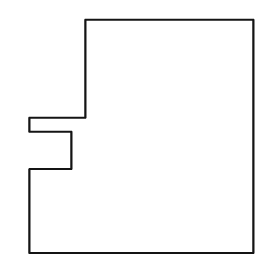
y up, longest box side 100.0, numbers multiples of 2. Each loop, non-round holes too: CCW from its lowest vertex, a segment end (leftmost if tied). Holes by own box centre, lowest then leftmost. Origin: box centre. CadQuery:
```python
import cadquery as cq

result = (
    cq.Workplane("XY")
    .moveTo(-48.0, -50.0)
    .lineTo(48.0, -50.0)
    .lineTo(48.0, 50.0)
    .lineTo(-24.0, 50.0)
    .lineTo(-24.0, 8.0)
    .lineTo(-48.0, 8.0)
    .lineTo(-48.0, 2.0)
    .lineTo(-30.0, 2.0)
    .lineTo(-30.0, -14.0)
    .lineTo(-48.0, -14.0)
    .close()
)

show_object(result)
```